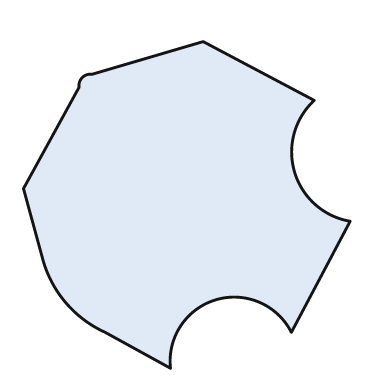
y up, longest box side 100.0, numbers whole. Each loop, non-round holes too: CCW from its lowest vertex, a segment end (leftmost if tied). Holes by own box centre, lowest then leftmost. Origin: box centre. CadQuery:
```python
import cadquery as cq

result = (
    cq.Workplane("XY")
    .moveTo(-5.0, -50.0)
    .threePointArc((9.0, -29.0), (32.0, -39.0))
    .lineTo(50.0, -5.0)
    .threePointArc((33.0, 10.0), (39.0, 32.0))
    .lineTo(5.0, 50.0)
    .lineTo(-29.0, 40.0)
    .threePointArc((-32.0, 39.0), (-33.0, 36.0))
    .lineTo(-50.0, 5.0)
    .lineTo(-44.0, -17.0)
    .threePointArc((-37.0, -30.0), (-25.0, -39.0))
    .close()
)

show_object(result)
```